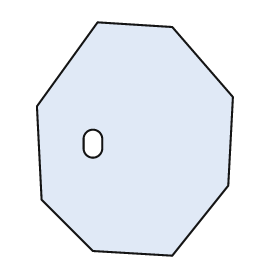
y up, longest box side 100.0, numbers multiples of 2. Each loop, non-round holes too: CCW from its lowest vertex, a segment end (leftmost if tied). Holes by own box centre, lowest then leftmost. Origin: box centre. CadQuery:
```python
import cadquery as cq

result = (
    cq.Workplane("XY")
    .moveTo(16.0, -50.0)
    .lineTo(40.0, -20.0)
    .lineTo(42.0, 18.0)
    .lineTo(16.0, 48.0)
    .lineTo(-16.0, 50.0)
    .lineTo(-42.0, 14.0)
    .lineTo(-40.0, -26.0)
    .lineTo(-18.0, -48.0)
    .close()
    .moveTo(-22.0, -4.0)
    .threePointArc((-18.0, -8.0), (-14.0, -4.0))
    .lineTo(-14.0, 0.0)
    .threePointArc((-18.0, 4.0), (-22.0, 0.0))
    .close()
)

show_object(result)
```